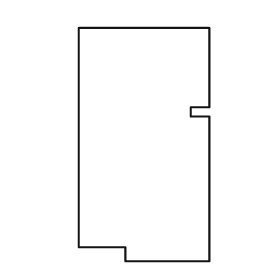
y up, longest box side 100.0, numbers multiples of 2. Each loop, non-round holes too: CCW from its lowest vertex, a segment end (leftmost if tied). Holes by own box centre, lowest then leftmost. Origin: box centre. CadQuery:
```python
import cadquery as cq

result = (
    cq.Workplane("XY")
    .moveTo(-8.0, -50.0)
    .lineTo(28.0, -50.0)
    .lineTo(28.0, 12.0)
    .lineTo(20.0, 12.0)
    .lineTo(20.0, 16.0)
    .lineTo(28.0, 16.0)
    .lineTo(28.0, 50.0)
    .lineTo(-28.0, 50.0)
    .lineTo(-28.0, -44.0)
    .lineTo(-8.0, -44.0)
    .close()
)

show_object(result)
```